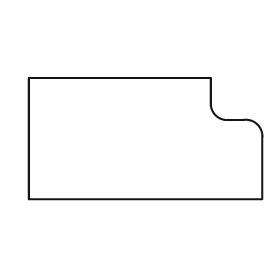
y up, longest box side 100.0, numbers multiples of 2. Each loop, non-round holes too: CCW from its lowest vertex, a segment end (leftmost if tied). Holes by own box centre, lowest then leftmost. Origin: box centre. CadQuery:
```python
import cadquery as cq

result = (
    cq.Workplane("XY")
    .moveTo(-50.0, -26.0)
    .lineTo(50.0, -26.0)
    .lineTo(50.0, 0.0)
    .threePointArc((48.0, 6.0), (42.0, 8.0))
    .lineTo(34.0, 8.0)
    .threePointArc((30.0, 10.0), (28.0, 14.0))
    .lineTo(28.0, 26.0)
    .lineTo(-50.0, 26.0)
    .close()
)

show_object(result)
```